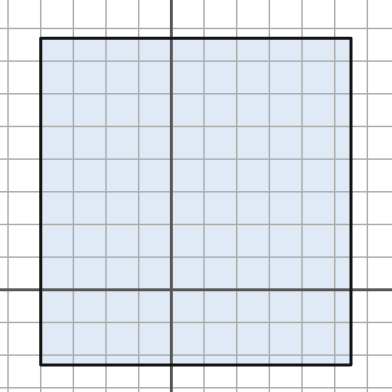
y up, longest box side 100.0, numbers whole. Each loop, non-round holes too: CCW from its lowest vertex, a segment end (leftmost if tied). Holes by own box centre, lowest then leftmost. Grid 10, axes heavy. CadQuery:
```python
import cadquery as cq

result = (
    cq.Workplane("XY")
    .moveTo(-40.0, -23.0)
    .lineTo(55.0, -23.0)
    .lineTo(55.0, 77.0)
    .lineTo(-40.0, 77.0)
    .close()
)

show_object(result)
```